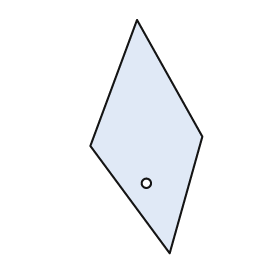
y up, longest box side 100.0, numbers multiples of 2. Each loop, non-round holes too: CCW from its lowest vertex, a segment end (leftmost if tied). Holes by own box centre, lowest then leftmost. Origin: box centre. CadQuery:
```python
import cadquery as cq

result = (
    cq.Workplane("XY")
    .moveTo(10.0, -50.0)
    .lineTo(24.0, 0.0)
    .lineTo(-4.0, 50.0)
    .lineTo(-24.0, -4.0)
    .close()
    .moveTo(0.0, -20.0)
    .circle(2.0)
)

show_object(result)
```